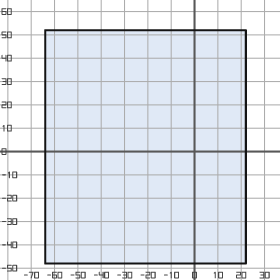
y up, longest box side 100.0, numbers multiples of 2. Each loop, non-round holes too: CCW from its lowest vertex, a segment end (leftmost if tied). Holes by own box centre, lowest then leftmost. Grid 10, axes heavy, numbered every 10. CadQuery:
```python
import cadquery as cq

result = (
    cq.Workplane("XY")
    .moveTo(-64.0, -48.0)
    .lineTo(22.0, -48.0)
    .lineTo(22.0, 52.0)
    .lineTo(-64.0, 52.0)
    .close()
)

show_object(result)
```